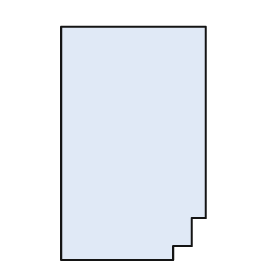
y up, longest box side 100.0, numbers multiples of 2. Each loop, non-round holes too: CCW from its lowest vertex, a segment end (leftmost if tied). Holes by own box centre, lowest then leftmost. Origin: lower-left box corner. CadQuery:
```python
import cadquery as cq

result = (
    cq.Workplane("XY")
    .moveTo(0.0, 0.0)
    .lineTo(48.0, 0.0)
    .lineTo(48.0, 6.0)
    .lineTo(56.0, 6.0)
    .lineTo(56.0, 18.0)
    .lineTo(62.0, 18.0)
    .lineTo(62.0, 100.0)
    .lineTo(0.0, 100.0)
    .close()
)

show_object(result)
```